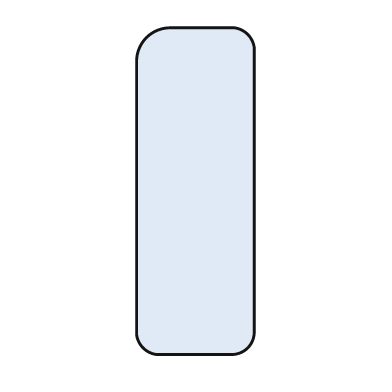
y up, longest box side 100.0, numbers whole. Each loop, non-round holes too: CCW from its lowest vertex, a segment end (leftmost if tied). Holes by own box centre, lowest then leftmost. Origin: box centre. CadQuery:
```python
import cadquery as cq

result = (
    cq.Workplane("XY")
    .moveTo(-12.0, -50.0)
    .lineTo(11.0, -50.0)
    .threePointArc((16.0, -48.0), (18.0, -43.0))
    .lineTo(18.0, 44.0)
    .threePointArc((16.0, 48.0), (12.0, 50.0))
    .lineTo(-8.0, 50.0)
    .threePointArc((-15.0, 47.0), (-18.0, 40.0))
    .lineTo(-18.0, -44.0)
    .threePointArc((-16.0, -48.0), (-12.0, -50.0))
    .close()
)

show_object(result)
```